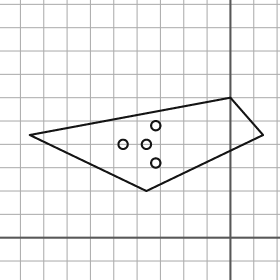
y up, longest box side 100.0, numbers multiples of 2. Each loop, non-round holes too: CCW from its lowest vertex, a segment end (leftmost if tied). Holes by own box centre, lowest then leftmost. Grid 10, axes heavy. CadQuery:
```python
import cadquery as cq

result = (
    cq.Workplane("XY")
    .moveTo(-36.0, 20.0)
    .lineTo(14.0, 44.0)
    .lineTo(0.0, 60.0)
    .lineTo(-86.0, 44.0)
    .close()
    .moveTo(-32.0, 32.0)
    .circle(2.0)
    .moveTo(-46.0, 40.0)
    .circle(2.0)
    .moveTo(-36.0, 40.0)
    .circle(2.0)
    .moveTo(-32.0, 48.0)
    .circle(2.0)
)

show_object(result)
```